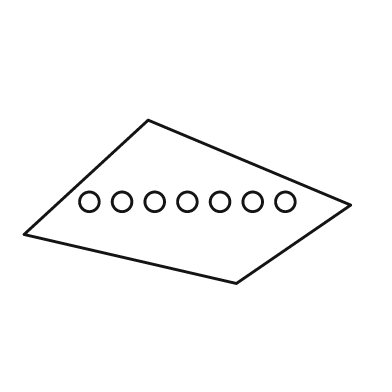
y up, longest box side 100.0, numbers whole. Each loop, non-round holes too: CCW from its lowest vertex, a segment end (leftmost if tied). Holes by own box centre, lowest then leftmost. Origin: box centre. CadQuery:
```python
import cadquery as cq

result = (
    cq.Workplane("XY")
    .moveTo(15.0, -25.0)
    .lineTo(50.0, -1.0)
    .lineTo(-12.0, 25.0)
    .lineTo(-50.0, -10.0)
    .close()
    .moveTo(-30.0, 0.0)
    .circle(3.0)
    .moveTo(-20.0, 0.0)
    .circle(3.0)
    .moveTo(-10.0, 0.0)
    .circle(3.0)
    .moveTo(0.0, 0.0)
    .circle(3.0)
    .moveTo(10.0, 0.0)
    .circle(3.0)
    .moveTo(20.0, 0.0)
    .circle(3.0)
    .moveTo(30.0, 0.0)
    .circle(3.0)
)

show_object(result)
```